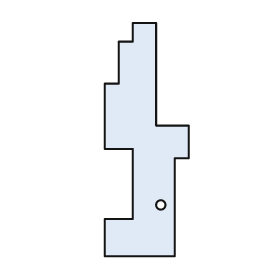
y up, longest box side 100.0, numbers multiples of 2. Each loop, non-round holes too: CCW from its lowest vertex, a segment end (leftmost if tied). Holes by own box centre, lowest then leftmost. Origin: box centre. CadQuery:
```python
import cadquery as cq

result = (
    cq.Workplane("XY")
    .moveTo(-18.0, -50.0)
    .lineTo(12.0, -50.0)
    .lineTo(12.0, -8.0)
    .lineTo(18.0, -8.0)
    .lineTo(18.0, 6.0)
    .lineTo(4.0, 6.0)
    .lineTo(4.0, 50.0)
    .lineTo(-6.0, 50.0)
    .lineTo(-6.0, 42.0)
    .lineTo(-12.0, 42.0)
    .lineTo(-12.0, 24.0)
    .lineTo(-18.0, 24.0)
    .lineTo(-18.0, -4.0)
    .lineTo(-6.0, -4.0)
    .lineTo(-6.0, -34.0)
    .lineTo(-18.0, -34.0)
    .close()
    .moveTo(6.0, -28.0)
    .circle(2.0)
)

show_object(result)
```